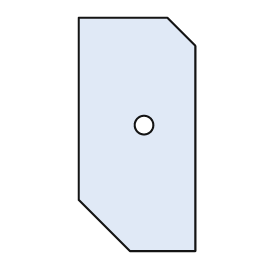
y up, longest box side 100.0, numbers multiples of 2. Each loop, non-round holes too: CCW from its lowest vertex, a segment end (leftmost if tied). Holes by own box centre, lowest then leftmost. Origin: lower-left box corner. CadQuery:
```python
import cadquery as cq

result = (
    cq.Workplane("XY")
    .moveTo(22.0, 0.0)
    .lineTo(50.0, 0.0)
    .lineTo(50.0, 88.0)
    .lineTo(38.0, 100.0)
    .lineTo(0.0, 100.0)
    .lineTo(0.0, 22.0)
    .close()
    .moveTo(28.0, 54.0)
    .circle(4.0)
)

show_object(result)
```